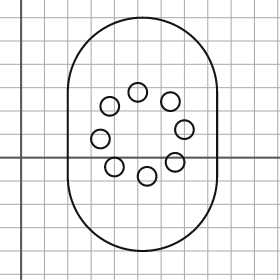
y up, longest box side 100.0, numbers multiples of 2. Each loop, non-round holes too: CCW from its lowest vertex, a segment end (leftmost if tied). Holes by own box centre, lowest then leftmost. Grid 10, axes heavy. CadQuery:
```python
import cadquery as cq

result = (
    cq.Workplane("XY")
    .moveTo(20.0, -8.0)
    .threePointArc((52.0, -40.0), (84.0, -8.0))
    .lineTo(84.0, 28.0)
    .threePointArc((52.0, 60.0), (20.0, 28.0))
    .close()
    .moveTo(54.0, -8.0)
    .circle(4.0)
    .moveTo(40.0, -4.0)
    .circle(4.0)
    .moveTo(66.0, -2.0)
    .circle(4.0)
    .moveTo(34.0, 8.0)
    .circle(4.0)
    .moveTo(70.0, 12.0)
    .circle(4.0)
    .moveTo(38.0, 22.0)
    .circle(4.0)
    .moveTo(64.0, 24.0)
    .circle(4.0)
    .moveTo(50.0, 28.0)
    .circle(4.0)
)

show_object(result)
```